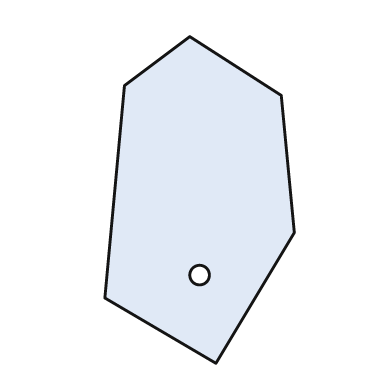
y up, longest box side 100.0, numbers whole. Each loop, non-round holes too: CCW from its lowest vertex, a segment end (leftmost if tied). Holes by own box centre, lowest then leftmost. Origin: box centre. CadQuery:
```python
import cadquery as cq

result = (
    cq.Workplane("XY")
    .moveTo(5.0, -50.0)
    .lineTo(29.0, -10.0)
    .lineTo(25.0, 32.0)
    .lineTo(-3.0, 50.0)
    .lineTo(-23.0, 35.0)
    .lineTo(-29.0, -30.0)
    .close()
    .moveTo(0.0, -23.0)
    .circle(3.0)
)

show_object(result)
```